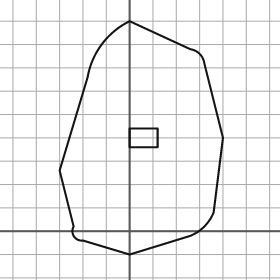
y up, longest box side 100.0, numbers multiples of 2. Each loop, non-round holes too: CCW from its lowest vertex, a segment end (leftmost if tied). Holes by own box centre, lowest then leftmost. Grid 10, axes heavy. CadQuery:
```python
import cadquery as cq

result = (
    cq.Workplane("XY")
    .moveTo(0.0, -10.0)
    .lineTo(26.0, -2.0)
    .threePointArc((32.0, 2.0), (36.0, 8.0))
    .lineTo(40.0, 40.0)
    .lineTo(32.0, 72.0)
    .threePointArc((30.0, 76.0), (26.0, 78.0))
    .lineTo(0.0, 90.0)
    .threePointArc((-12.0, 80.0), (-18.0, 66.0))
    .lineTo(-30.0, 26.0)
    .lineTo(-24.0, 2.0)
    .threePointArc((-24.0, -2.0), (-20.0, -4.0))
    .close()
    .moveTo(0.0, 36.0)
    .lineTo(12.0, 36.0)
    .lineTo(12.0, 44.0)
    .lineTo(0.0, 44.0)
    .close()
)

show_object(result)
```